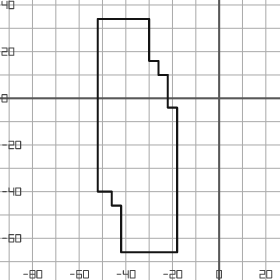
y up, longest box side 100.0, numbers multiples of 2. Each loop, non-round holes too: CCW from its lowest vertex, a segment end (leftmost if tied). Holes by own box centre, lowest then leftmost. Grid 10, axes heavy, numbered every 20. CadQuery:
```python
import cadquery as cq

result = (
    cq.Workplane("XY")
    .moveTo(-42.0, -66.0)
    .lineTo(-18.0, -66.0)
    .lineTo(-18.0, -4.0)
    .lineTo(-22.0, -4.0)
    .lineTo(-22.0, 10.0)
    .lineTo(-26.0, 10.0)
    .lineTo(-26.0, 16.0)
    .lineTo(-30.0, 16.0)
    .lineTo(-30.0, 34.0)
    .lineTo(-52.0, 34.0)
    .lineTo(-52.0, -40.0)
    .lineTo(-46.0, -40.0)
    .lineTo(-46.0, -46.0)
    .lineTo(-42.0, -46.0)
    .close()
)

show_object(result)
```